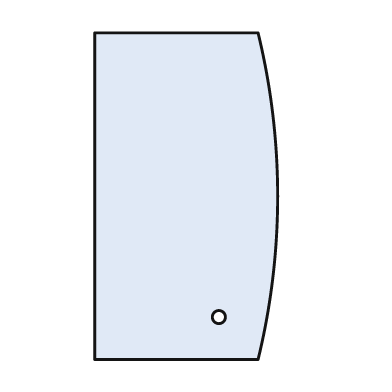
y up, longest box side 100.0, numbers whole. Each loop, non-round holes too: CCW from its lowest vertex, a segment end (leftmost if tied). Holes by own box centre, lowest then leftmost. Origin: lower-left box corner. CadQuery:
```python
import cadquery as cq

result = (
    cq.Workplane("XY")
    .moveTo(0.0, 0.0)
    .lineTo(50.0, 0.0)
    .threePointArc((56.0, 50.0), (50.0, 100.0))
    .lineTo(0.0, 100.0)
    .close()
    .moveTo(38.0, 13.0)
    .circle(2.0)
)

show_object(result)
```